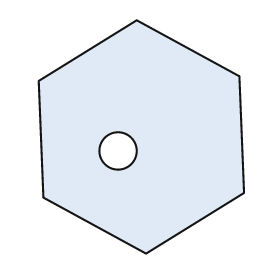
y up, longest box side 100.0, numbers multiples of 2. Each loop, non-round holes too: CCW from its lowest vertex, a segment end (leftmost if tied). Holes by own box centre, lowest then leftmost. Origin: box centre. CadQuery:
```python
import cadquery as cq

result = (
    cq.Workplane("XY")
    .moveTo(2.0, -50.0)
    .lineTo(44.0, -24.0)
    .lineTo(42.0, 26.0)
    .lineTo(-2.0, 50.0)
    .lineTo(-44.0, 24.0)
    .lineTo(-42.0, -26.0)
    .close()
    .moveTo(-10.0, -6.0)
    .circle(8.0)
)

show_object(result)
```